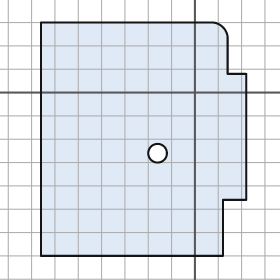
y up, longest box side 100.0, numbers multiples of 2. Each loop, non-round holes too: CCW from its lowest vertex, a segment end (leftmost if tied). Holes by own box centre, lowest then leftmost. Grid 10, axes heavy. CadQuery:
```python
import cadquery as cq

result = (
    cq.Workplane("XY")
    .moveTo(-66.0, -70.0)
    .lineTo(12.0, -70.0)
    .lineTo(12.0, -46.0)
    .lineTo(22.0, -46.0)
    .lineTo(22.0, 8.0)
    .lineTo(14.0, 8.0)
    .lineTo(14.0, 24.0)
    .threePointArc((12.0, 28.0), (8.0, 30.0))
    .lineTo(-66.0, 30.0)
    .close()
    .moveTo(-16.0, -26.0)
    .circle(4.0)
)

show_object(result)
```